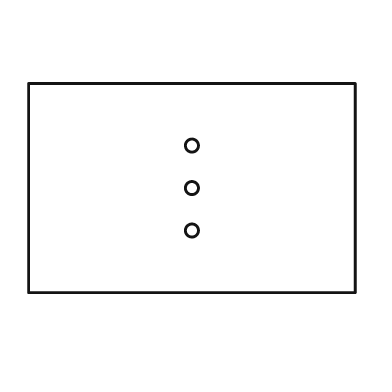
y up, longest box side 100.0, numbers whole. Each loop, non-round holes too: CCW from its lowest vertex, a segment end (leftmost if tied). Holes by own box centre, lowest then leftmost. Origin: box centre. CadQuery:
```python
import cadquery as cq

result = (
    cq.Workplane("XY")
    .moveTo(-50.0, -32.0)
    .lineTo(50.0, -32.0)
    .lineTo(50.0, 32.0)
    .lineTo(-50.0, 32.0)
    .close()
    .moveTo(0.0, -13.0)
    .circle(2.0)
    .moveTo(0.0, 0.0)
    .circle(2.0)
    .moveTo(0.0, 13.0)
    .circle(2.0)
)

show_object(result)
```